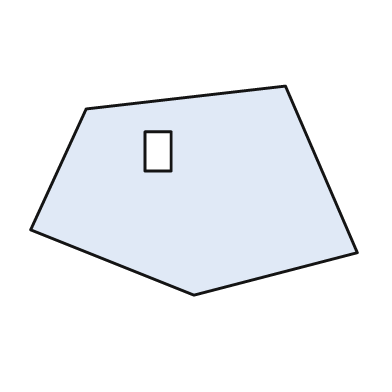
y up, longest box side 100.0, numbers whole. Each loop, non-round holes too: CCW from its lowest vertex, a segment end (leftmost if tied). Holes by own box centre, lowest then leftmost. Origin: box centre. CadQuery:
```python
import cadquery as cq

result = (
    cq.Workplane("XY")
    .moveTo(0.0, -32.0)
    .lineTo(50.0, -19.0)
    .lineTo(28.0, 32.0)
    .lineTo(-33.0, 25.0)
    .lineTo(-50.0, -12.0)
    .close()
    .moveTo(-15.0, 6.0)
    .lineTo(-7.0, 6.0)
    .lineTo(-7.0, 18.0)
    .lineTo(-15.0, 18.0)
    .close()
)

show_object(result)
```